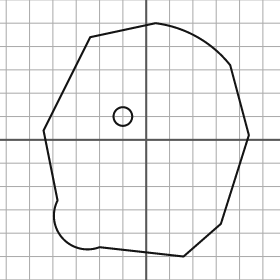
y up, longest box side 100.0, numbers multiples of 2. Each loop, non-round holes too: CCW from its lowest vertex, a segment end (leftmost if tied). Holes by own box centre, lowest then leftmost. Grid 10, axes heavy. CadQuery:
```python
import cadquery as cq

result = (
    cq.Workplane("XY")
    .moveTo(16.0, -50.0)
    .lineTo(32.0, -36.0)
    .lineTo(44.0, 2.0)
    .lineTo(36.0, 32.0)
    .threePointArc((22.0, 44.0), (4.0, 50.0))
    .lineTo(-24.0, 44.0)
    .lineTo(-44.0, 4.0)
    .lineTo(-38.0, -26.0)
    .threePointArc((-36.0, -42.0), (-20.0, -46.0))
    .close()
    .moveTo(-10.0, 10.0)
    .circle(4.0)
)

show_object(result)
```